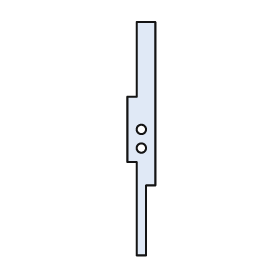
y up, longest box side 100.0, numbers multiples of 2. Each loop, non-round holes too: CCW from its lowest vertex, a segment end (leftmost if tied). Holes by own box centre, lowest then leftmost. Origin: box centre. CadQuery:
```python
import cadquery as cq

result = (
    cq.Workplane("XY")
    .moveTo(-2.0, -50.0)
    .lineTo(2.0, -50.0)
    .lineTo(2.0, -20.0)
    .lineTo(6.0, -20.0)
    .lineTo(6.0, 50.0)
    .lineTo(-2.0, 50.0)
    .lineTo(-2.0, 18.0)
    .lineTo(-6.0, 18.0)
    .lineTo(-6.0, -10.0)
    .lineTo(-2.0, -10.0)
    .close()
    .moveTo(0.0, -4.0)
    .circle(2.0)
    .moveTo(0.0, 4.0)
    .circle(2.0)
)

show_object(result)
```